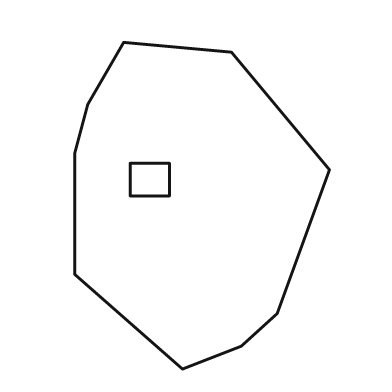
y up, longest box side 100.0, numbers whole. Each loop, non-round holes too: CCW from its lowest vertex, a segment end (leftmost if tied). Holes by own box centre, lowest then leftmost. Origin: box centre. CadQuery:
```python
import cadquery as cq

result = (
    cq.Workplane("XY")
    .moveTo(-6.0, -50.0)
    .lineTo(12.0, -43.0)
    .lineTo(23.0, -33.0)
    .lineTo(39.0, 11.0)
    .lineTo(9.0, 47.0)
    .lineTo(-24.0, 50.0)
    .lineTo(-35.0, 31.0)
    .lineTo(-39.0, 16.0)
    .lineTo(-39.0, -21.0)
    .close()
    .moveTo(-22.0, 3.0)
    .lineTo(-10.0, 3.0)
    .lineTo(-10.0, 13.0)
    .lineTo(-22.0, 13.0)
    .close()
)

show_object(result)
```